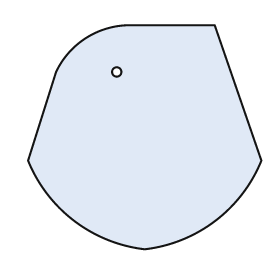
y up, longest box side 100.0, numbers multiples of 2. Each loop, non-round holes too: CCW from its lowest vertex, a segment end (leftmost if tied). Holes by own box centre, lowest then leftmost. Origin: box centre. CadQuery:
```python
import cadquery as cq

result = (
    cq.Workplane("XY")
    .moveTo(0.0, -48.0)
    .threePointArc((30.0, -36.0), (50.0, -10.0))
    .lineTo(30.0, 48.0)
    .lineTo(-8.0, 48.0)
    .threePointArc((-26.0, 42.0), (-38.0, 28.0))
    .lineTo(-50.0, -10.0)
    .threePointArc((-30.0, -36.0), (0.0, -48.0))
    .close()
    .moveTo(-12.0, 28.0)
    .circle(2.0)
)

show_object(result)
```